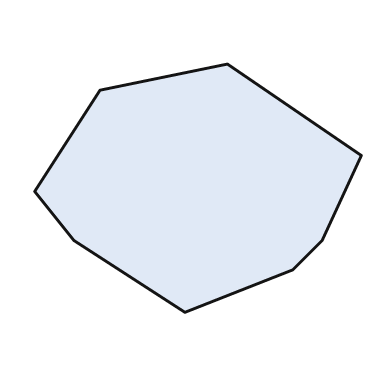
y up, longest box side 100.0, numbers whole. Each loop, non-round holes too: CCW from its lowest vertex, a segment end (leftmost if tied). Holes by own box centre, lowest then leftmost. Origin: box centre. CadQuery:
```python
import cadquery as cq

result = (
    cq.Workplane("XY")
    .moveTo(-4.0, -38.0)
    .lineTo(29.0, -25.0)
    .lineTo(38.0, -16.0)
    .lineTo(50.0, 10.0)
    .lineTo(9.0, 38.0)
    .lineTo(-30.0, 30.0)
    .lineTo(-50.0, -1.0)
    .lineTo(-38.0, -16.0)
    .close()
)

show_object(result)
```